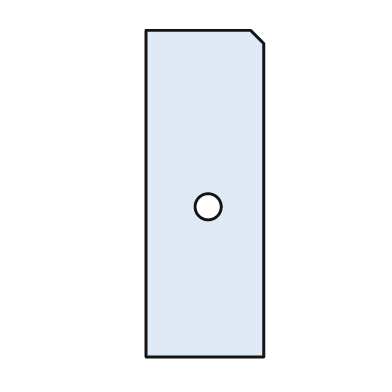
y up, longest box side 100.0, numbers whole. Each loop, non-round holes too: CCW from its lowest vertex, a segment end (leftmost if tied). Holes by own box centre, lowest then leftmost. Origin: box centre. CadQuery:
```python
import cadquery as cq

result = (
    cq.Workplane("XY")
    .moveTo(-18.0, -50.0)
    .lineTo(18.0, -50.0)
    .lineTo(18.0, 46.0)
    .lineTo(14.0, 50.0)
    .lineTo(-18.0, 50.0)
    .close()
    .moveTo(1.0, -4.0)
    .circle(4.0)
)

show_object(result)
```